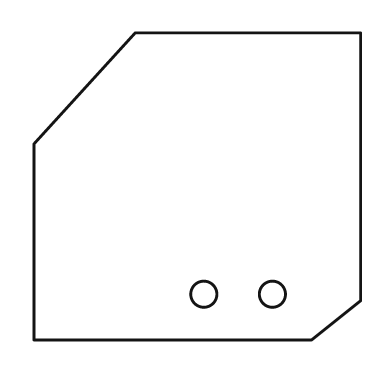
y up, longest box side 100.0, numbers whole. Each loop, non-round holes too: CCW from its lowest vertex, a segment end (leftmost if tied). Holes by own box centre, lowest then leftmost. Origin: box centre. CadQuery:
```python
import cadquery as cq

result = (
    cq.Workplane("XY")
    .moveTo(-50.0, -47.0)
    .lineTo(35.0, -47.0)
    .lineTo(50.0, -35.0)
    .lineTo(50.0, 47.0)
    .lineTo(-19.0, 47.0)
    .lineTo(-50.0, 13.0)
    .close()
    .moveTo(2.0, -33.0)
    .circle(4.0)
    .moveTo(23.0, -33.0)
    .circle(4.0)
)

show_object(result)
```